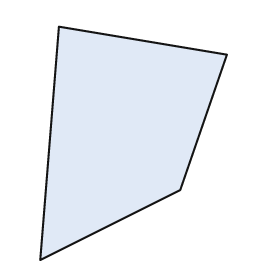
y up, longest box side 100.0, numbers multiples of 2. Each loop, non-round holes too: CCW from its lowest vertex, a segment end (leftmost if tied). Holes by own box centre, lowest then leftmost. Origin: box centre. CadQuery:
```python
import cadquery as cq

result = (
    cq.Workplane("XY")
    .moveTo(-40.0, -50.0)
    .lineTo(20.0, -20.0)
    .lineTo(40.0, 38.0)
    .lineTo(-32.0, 50.0)
    .close()
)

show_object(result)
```